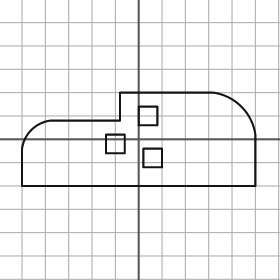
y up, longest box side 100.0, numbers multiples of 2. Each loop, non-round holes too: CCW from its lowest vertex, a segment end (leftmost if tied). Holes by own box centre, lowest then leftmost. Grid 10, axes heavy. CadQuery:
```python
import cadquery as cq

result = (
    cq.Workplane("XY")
    .moveTo(-50.0, -20.0)
    .lineTo(50.0, -20.0)
    .lineTo(50.0, 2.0)
    .threePointArc((44.0, 14.0), (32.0, 20.0))
    .lineTo(-8.0, 20.0)
    .lineTo(-8.0, 8.0)
    .lineTo(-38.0, 8.0)
    .threePointArc((-46.0, 4.0), (-50.0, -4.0))
    .close()
    .moveTo(2.0, -12.0)
    .lineTo(10.0, -12.0)
    .lineTo(10.0, -4.0)
    .lineTo(2.0, -4.0)
    .close()
    .moveTo(-14.0, -6.0)
    .lineTo(-6.0, -6.0)
    .lineTo(-6.0, 2.0)
    .lineTo(-14.0, 2.0)
    .close()
    .moveTo(0.0, 6.0)
    .lineTo(8.0, 6.0)
    .lineTo(8.0, 14.0)
    .lineTo(0.0, 14.0)
    .close()
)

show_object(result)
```